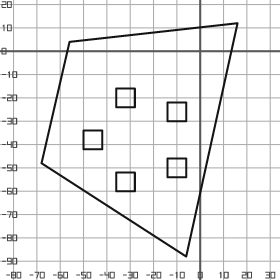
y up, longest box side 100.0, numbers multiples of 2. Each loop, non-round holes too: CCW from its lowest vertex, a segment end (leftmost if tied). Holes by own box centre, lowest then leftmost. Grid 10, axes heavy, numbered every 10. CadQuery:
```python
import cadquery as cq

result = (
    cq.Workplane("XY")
    .moveTo(-6.0, -88.0)
    .lineTo(16.0, 12.0)
    .lineTo(-56.0, 4.0)
    .lineTo(-68.0, -48.0)
    .close()
    .moveTo(-36.0, -60.0)
    .lineTo(-28.0, -60.0)
    .lineTo(-28.0, -52.0)
    .lineTo(-36.0, -52.0)
    .close()
    .moveTo(-14.0, -54.0)
    .lineTo(-6.0, -54.0)
    .lineTo(-6.0, -46.0)
    .lineTo(-14.0, -46.0)
    .close()
    .moveTo(-50.0, -42.0)
    .lineTo(-42.0, -42.0)
    .lineTo(-42.0, -34.0)
    .lineTo(-50.0, -34.0)
    .close()
    .moveTo(-14.0, -30.0)
    .lineTo(-6.0, -30.0)
    .lineTo(-6.0, -22.0)
    .lineTo(-14.0, -22.0)
    .close()
    .moveTo(-36.0, -24.0)
    .lineTo(-28.0, -24.0)
    .lineTo(-28.0, -16.0)
    .lineTo(-36.0, -16.0)
    .close()
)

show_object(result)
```